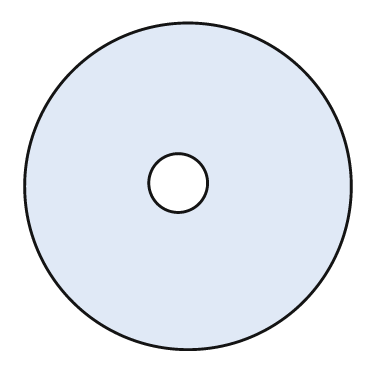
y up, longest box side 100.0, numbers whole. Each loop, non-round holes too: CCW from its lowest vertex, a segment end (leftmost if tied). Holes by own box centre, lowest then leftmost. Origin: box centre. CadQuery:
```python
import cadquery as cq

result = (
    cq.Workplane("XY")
    .moveTo(0.0, 0.0)
    .circle(50.0)
    .moveTo(-3.0, 1.0)
    .circle(9.0)
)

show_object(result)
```